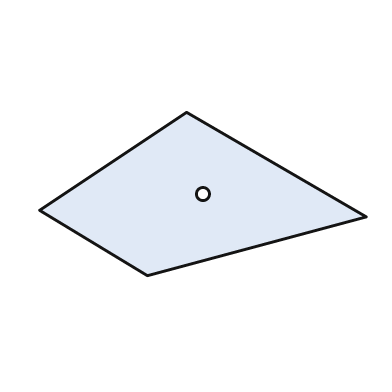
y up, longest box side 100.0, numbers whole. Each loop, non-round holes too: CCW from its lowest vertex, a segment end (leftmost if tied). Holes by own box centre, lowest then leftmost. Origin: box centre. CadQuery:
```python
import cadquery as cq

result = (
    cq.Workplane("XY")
    .moveTo(-17.0, -25.0)
    .lineTo(50.0, -7.0)
    .lineTo(-5.0, 25.0)
    .lineTo(-50.0, -5.0)
    .close()
    .moveTo(0.0, 0.0)
    .circle(2.0)
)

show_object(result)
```